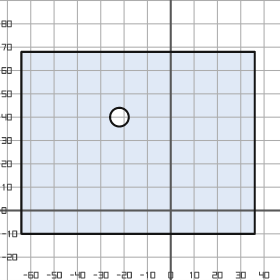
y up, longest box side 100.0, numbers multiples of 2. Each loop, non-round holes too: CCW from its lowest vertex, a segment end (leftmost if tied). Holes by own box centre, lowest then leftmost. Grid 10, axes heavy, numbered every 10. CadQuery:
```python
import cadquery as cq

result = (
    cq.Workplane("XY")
    .moveTo(-64.0, -10.0)
    .lineTo(36.0, -10.0)
    .lineTo(36.0, 68.0)
    .lineTo(-64.0, 68.0)
    .close()
    .moveTo(-22.0, 40.0)
    .circle(4.0)
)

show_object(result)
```